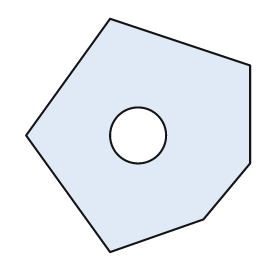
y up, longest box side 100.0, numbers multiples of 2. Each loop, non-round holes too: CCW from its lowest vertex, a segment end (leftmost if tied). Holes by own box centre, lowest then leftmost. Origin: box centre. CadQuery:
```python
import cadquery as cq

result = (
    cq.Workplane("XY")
    .moveTo(-12.0, -50.0)
    .lineTo(28.0, -36.0)
    .lineTo(48.0, -12.0)
    .lineTo(48.0, 30.0)
    .lineTo(-12.0, 50.0)
    .lineTo(-48.0, 0.0)
    .close()
    .moveTo(0.0, 0.0)
    .circle(12.0)
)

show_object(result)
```